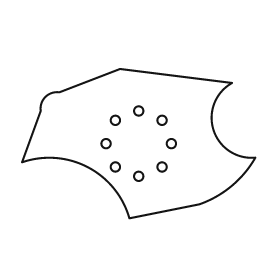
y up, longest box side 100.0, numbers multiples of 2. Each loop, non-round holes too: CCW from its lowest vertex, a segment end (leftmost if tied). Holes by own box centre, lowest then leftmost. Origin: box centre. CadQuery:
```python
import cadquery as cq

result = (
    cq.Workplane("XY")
    .moveTo(-4.0, -32.0)
    .lineTo(26.0, -26.0)
    .threePointArc((40.0, -18.0), (50.0, -6.0))
    .threePointArc((32.0, 6.0), (40.0, 26.0))
    .lineTo(-8.0, 32.0)
    .lineTo(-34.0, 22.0)
    .threePointArc((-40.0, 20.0), (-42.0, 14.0))
    .lineTo(-50.0, -8.0)
    .threePointArc((-22.0, -10.0), (-4.0, -32.0))
    .close()
    .moveTo(0.0, -14.0)
    .circle(2.0)
    .moveTo(-10.0, -10.0)
    .circle(2.0)
    .moveTo(10.0, -10.0)
    .circle(2.0)
    .moveTo(-14.0, 0.0)
    .circle(2.0)
    .moveTo(14.0, 0.0)
    .circle(2.0)
    .moveTo(-10.0, 10.0)
    .circle(2.0)
    .moveTo(10.0, 10.0)
    .circle(2.0)
    .moveTo(0.0, 14.0)
    .circle(2.0)
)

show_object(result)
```